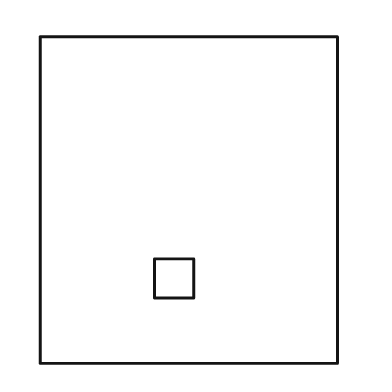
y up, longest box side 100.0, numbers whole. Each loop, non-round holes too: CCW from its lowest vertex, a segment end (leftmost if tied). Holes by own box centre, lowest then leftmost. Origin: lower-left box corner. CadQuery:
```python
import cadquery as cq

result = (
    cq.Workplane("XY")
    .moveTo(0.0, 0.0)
    .lineTo(91.0, 0.0)
    .lineTo(91.0, 100.0)
    .lineTo(0.0, 100.0)
    .close()
    .moveTo(35.0, 20.0)
    .lineTo(47.0, 20.0)
    .lineTo(47.0, 32.0)
    .lineTo(35.0, 32.0)
    .close()
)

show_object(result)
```